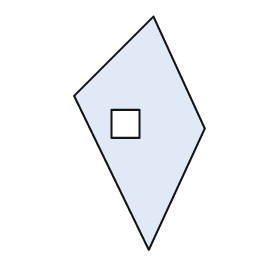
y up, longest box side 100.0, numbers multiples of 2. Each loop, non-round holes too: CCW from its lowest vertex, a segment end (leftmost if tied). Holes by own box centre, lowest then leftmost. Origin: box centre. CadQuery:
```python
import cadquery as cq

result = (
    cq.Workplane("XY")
    .moveTo(4.0, -50.0)
    .lineTo(28.0, 2.0)
    .lineTo(6.0, 50.0)
    .lineTo(-28.0, 16.0)
    .close()
    .moveTo(-12.0, -2.0)
    .lineTo(0.0, -2.0)
    .lineTo(0.0, 10.0)
    .lineTo(-12.0, 10.0)
    .close()
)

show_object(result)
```